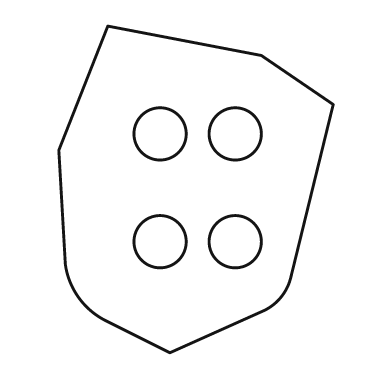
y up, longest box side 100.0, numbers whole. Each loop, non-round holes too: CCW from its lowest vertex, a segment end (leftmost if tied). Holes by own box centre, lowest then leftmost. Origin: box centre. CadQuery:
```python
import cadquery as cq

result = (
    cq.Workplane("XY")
    .moveTo(-8.0, -50.0)
    .lineTo(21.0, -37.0)
    .threePointArc((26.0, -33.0), (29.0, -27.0))
    .lineTo(42.0, 26.0)
    .lineTo(20.0, 41.0)
    .lineTo(-27.0, 50.0)
    .lineTo(-42.0, 12.0)
    .lineTo(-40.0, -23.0)
    .threePointArc((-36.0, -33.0), (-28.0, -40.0))
    .close()
    .moveTo(-11.0, -16.0)
    .circle(8.0)
    .moveTo(12.0, -16.0)
    .circle(8.0)
    .moveTo(-11.0, 17.0)
    .circle(8.0)
    .moveTo(12.0, 17.0)
    .circle(8.0)
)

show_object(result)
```